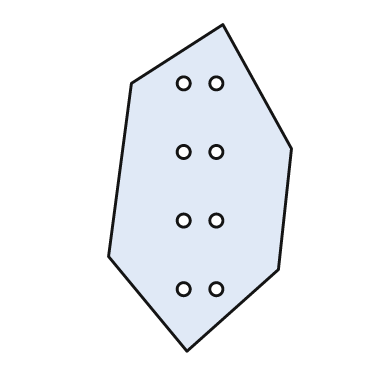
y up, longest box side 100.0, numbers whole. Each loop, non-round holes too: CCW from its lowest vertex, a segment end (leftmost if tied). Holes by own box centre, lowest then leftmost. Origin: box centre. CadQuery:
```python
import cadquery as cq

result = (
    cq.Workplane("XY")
    .moveTo(-4.0, -50.0)
    .lineTo(24.0, -25.0)
    .lineTo(28.0, 12.0)
    .lineTo(7.0, 50.0)
    .lineTo(-21.0, 32.0)
    .lineTo(-28.0, -21.0)
    .close()
    .moveTo(-5.0, -31.0)
    .circle(2.0)
    .moveTo(5.0, -31.0)
    .circle(2.0)
    .moveTo(-5.0, -10.0)
    .circle(2.0)
    .moveTo(5.0, -10.0)
    .circle(2.0)
    .moveTo(-5.0, 11.0)
    .circle(2.0)
    .moveTo(5.0, 11.0)
    .circle(2.0)
    .moveTo(-5.0, 32.0)
    .circle(2.0)
    .moveTo(5.0, 32.0)
    .circle(2.0)
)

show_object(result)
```